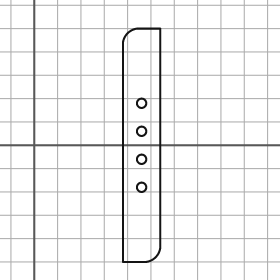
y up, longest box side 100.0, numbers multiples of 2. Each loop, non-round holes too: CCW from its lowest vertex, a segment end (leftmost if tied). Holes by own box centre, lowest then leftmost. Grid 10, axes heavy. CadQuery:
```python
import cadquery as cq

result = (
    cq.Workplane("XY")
    .moveTo(38.0, -50.0)
    .lineTo(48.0, -50.0)
    .threePointArc((52.0, -48.0), (54.0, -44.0))
    .lineTo(54.0, 50.0)
    .lineTo(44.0, 50.0)
    .threePointArc((40.0, 48.0), (38.0, 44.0))
    .close()
    .moveTo(46.0, -18.0)
    .circle(2.0)
    .moveTo(46.0, -6.0)
    .circle(2.0)
    .moveTo(46.0, 6.0)
    .circle(2.0)
    .moveTo(46.0, 18.0)
    .circle(2.0)
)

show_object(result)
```